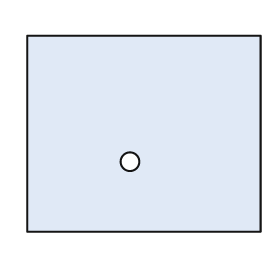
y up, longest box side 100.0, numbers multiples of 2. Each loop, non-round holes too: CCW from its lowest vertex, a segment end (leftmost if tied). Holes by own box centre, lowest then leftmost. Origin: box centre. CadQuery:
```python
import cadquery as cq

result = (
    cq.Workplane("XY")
    .moveTo(-50.0, -42.0)
    .lineTo(50.0, -42.0)
    .lineTo(50.0, 42.0)
    .lineTo(-50.0, 42.0)
    .close()
    .moveTo(-6.0, -12.0)
    .circle(4.0)
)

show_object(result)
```